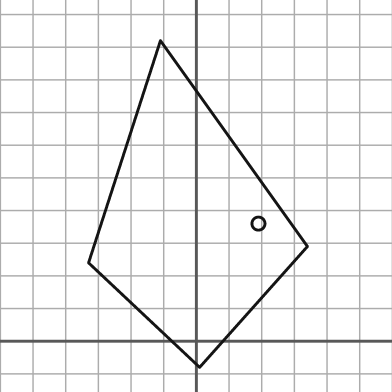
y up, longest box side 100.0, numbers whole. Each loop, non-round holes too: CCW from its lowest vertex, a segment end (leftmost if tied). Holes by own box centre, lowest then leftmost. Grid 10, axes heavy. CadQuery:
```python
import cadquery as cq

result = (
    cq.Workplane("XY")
    .moveTo(1.0, -8.0)
    .lineTo(34.0, 29.0)
    .lineTo(-11.0, 92.0)
    .lineTo(-33.0, 24.0)
    .close()
    .moveTo(19.0, 36.0)
    .circle(2.0)
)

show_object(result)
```